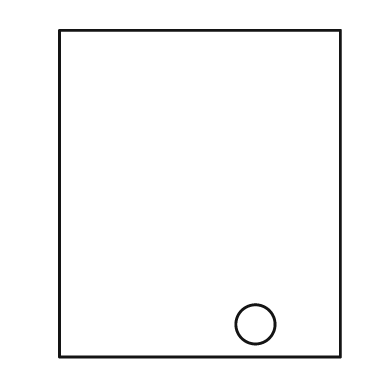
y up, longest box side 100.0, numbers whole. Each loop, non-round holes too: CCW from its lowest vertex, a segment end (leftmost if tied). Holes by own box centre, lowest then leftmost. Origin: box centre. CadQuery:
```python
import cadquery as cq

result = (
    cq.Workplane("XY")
    .moveTo(-43.0, -50.0)
    .lineTo(43.0, -50.0)
    .lineTo(43.0, 50.0)
    .lineTo(-43.0, 50.0)
    .close()
    .moveTo(17.0, -40.0)
    .circle(6.0)
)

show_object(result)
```